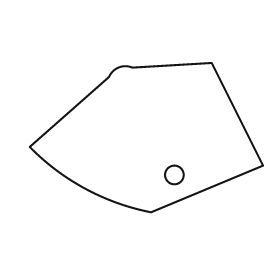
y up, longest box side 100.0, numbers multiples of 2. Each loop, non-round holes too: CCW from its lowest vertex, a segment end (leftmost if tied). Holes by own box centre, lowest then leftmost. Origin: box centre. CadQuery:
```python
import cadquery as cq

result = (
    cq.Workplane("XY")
    .moveTo(2.0, -32.0)
    .lineTo(50.0, -12.0)
    .lineTo(28.0, 32.0)
    .lineTo(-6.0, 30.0)
    .threePointArc((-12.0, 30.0), (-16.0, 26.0))
    .lineTo(-50.0, -4.0)
    .threePointArc((-26.0, -22.0), (2.0, -32.0))
    .close()
    .moveTo(12.0, -16.0)
    .circle(4.0)
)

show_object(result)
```